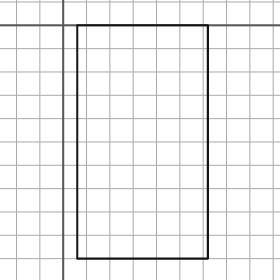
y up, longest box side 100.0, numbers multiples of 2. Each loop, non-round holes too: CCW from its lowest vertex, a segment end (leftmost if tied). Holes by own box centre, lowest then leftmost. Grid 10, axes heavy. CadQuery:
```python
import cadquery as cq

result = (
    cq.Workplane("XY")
    .moveTo(6.0, -100.0)
    .lineTo(62.0, -100.0)
    .lineTo(62.0, 0.0)
    .lineTo(6.0, 0.0)
    .close()
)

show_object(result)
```